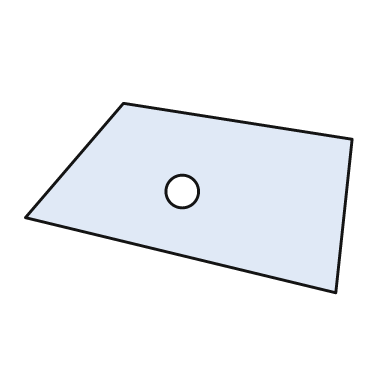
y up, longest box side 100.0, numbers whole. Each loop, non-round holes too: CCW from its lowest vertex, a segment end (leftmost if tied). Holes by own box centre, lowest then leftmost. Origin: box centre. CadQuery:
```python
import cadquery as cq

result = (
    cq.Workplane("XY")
    .moveTo(45.0, -29.0)
    .lineTo(50.0, 18.0)
    .lineTo(-20.0, 29.0)
    .lineTo(-50.0, -6.0)
    .close()
    .moveTo(-2.0, 2.0)
    .circle(5.0)
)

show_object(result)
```